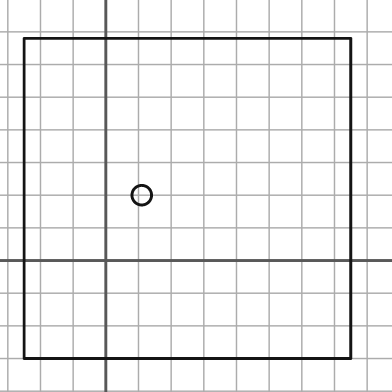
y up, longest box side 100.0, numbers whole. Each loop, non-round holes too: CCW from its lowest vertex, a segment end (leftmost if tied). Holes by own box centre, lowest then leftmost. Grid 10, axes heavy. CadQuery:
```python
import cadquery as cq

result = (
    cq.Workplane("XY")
    .moveTo(-25.0, -30.0)
    .lineTo(75.0, -30.0)
    .lineTo(75.0, 68.0)
    .lineTo(-25.0, 68.0)
    .close()
    .moveTo(11.0, 20.0)
    .circle(3.0)
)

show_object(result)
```